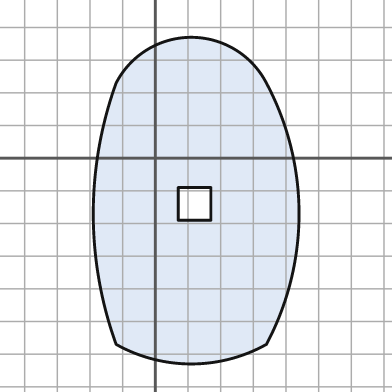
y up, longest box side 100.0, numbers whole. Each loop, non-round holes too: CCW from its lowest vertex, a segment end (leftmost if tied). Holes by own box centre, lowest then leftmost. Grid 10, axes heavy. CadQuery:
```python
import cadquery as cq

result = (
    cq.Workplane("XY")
    .moveTo(-12.0, -57.0)
    .threePointArc((11.0, -63.0), (34.0, -57.0))
    .threePointArc((44.0, -17.0), (34.0, 23.0))
    .threePointArc((11.0, 37.0), (-12.0, 23.0))
    .threePointArc((-19.0, -17.0), (-12.0, -57.0))
    .close()
    .moveTo(7.0, -19.0)
    .lineTo(17.0, -19.0)
    .lineTo(17.0, -9.0)
    .lineTo(7.0, -9.0)
    .close()
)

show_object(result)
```